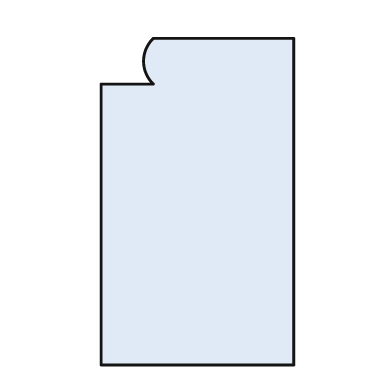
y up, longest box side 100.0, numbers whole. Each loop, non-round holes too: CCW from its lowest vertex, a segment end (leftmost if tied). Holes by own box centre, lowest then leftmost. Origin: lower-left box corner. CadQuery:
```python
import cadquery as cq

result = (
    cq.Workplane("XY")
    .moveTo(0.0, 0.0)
    .lineTo(59.0, 0.0)
    .lineTo(59.0, 100.0)
    .lineTo(16.0, 100.0)
    .threePointArc((13.0, 93.0), (16.0, 86.0))
    .lineTo(0.0, 86.0)
    .close()
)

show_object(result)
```